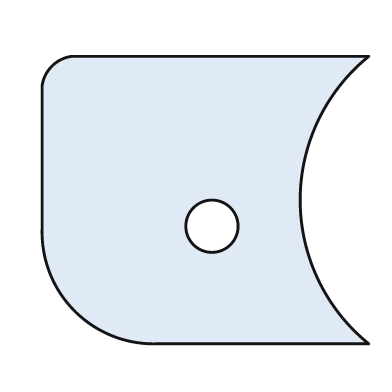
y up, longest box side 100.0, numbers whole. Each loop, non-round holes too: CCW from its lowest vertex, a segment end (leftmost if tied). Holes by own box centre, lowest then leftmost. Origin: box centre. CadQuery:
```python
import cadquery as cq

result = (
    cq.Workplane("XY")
    .moveTo(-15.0, -44.0)
    .lineTo(50.0, -44.0)
    .threePointArc((29.0, 0.0), (50.0, 44.0))
    .lineTo(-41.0, 44.0)
    .threePointArc((-47.0, 41.0), (-50.0, 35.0))
    .lineTo(-50.0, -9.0)
    .threePointArc((-40.0, -34.0), (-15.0, -44.0))
    .close()
    .moveTo(2.0, -8.0)
    .circle(8.0)
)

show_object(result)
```